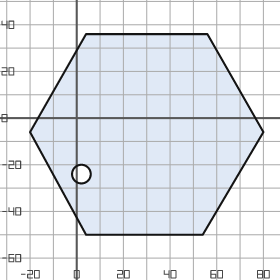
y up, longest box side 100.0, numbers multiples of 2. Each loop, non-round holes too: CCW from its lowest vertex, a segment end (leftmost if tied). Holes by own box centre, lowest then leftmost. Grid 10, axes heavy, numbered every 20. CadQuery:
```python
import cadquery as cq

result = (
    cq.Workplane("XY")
    .moveTo(4.0, -50.0)
    .lineTo(54.0, -50.0)
    .lineTo(80.0, -6.0)
    .lineTo(56.0, 36.0)
    .lineTo(4.0, 36.0)
    .lineTo(-20.0, -6.0)
    .close()
    .moveTo(2.0, -24.0)
    .circle(4.0)
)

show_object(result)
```